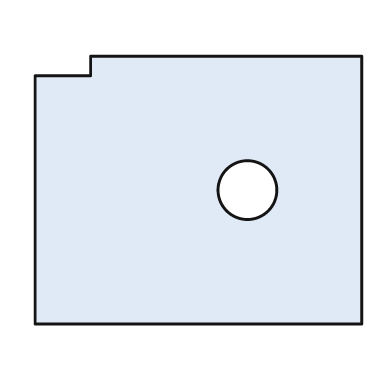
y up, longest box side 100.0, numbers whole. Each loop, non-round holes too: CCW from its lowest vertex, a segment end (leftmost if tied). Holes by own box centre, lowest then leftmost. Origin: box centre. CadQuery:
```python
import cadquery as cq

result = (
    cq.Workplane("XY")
    .moveTo(-50.0, -41.0)
    .lineTo(50.0, -41.0)
    .lineTo(50.0, 41.0)
    .lineTo(-33.0, 41.0)
    .lineTo(-33.0, 35.0)
    .lineTo(-50.0, 35.0)
    .close()
    .moveTo(15.0, 0.0)
    .circle(9.0)
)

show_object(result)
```